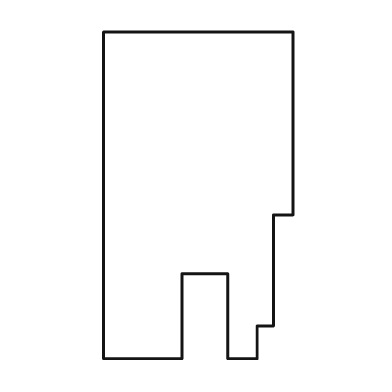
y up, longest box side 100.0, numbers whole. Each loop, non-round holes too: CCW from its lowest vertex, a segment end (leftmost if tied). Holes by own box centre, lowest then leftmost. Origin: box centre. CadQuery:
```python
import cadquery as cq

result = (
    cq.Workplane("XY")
    .moveTo(-29.0, -50.0)
    .lineTo(-5.0, -50.0)
    .lineTo(-5.0, -24.0)
    .lineTo(9.0, -24.0)
    .lineTo(9.0, -50.0)
    .lineTo(18.0, -50.0)
    .lineTo(18.0, -40.0)
    .lineTo(23.0, -40.0)
    .lineTo(23.0, -6.0)
    .lineTo(29.0, -6.0)
    .lineTo(29.0, 50.0)
    .lineTo(-29.0, 50.0)
    .close()
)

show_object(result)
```